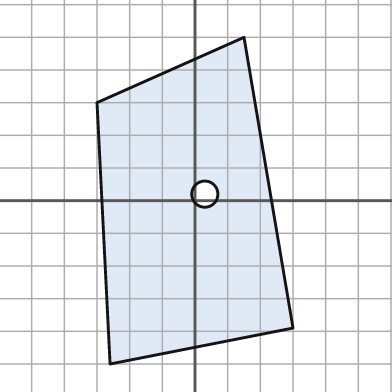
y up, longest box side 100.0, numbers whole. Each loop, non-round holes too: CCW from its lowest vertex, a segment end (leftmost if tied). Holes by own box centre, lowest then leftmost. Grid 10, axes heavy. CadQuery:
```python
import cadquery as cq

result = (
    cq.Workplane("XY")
    .moveTo(-26.0, -50.0)
    .lineTo(30.0, -39.0)
    .lineTo(15.0, 50.0)
    .lineTo(-30.0, 30.0)
    .close()
    .moveTo(3.0, 2.0)
    .circle(4.0)
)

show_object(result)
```